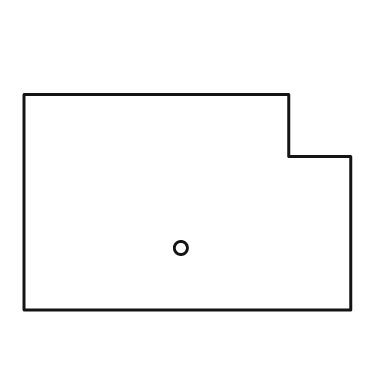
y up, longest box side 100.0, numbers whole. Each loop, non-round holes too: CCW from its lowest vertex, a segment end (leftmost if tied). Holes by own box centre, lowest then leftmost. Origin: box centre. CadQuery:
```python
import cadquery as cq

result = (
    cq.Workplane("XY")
    .moveTo(-50.0, -33.0)
    .lineTo(50.0, -33.0)
    .lineTo(50.0, 14.0)
    .lineTo(31.0, 14.0)
    .lineTo(31.0, 33.0)
    .lineTo(-50.0, 33.0)
    .close()
    .moveTo(-2.0, -14.0)
    .circle(2.0)
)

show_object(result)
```